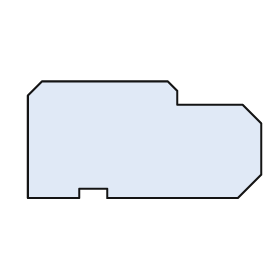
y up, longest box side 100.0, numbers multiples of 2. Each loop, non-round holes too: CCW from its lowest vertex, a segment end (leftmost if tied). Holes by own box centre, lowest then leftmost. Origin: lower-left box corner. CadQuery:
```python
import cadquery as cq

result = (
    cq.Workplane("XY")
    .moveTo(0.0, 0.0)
    .lineTo(22.0, 0.0)
    .lineTo(22.0, 4.0)
    .lineTo(34.0, 4.0)
    .lineTo(34.0, 0.0)
    .lineTo(90.0, 0.0)
    .lineTo(100.0, 10.0)
    .lineTo(100.0, 32.0)
    .lineTo(92.0, 40.0)
    .lineTo(64.0, 40.0)
    .lineTo(64.0, 46.0)
    .lineTo(60.0, 50.0)
    .lineTo(6.0, 50.0)
    .lineTo(0.0, 44.0)
    .close()
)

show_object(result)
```